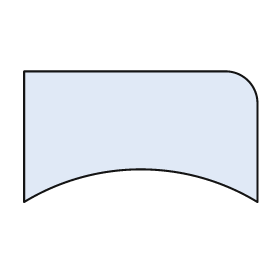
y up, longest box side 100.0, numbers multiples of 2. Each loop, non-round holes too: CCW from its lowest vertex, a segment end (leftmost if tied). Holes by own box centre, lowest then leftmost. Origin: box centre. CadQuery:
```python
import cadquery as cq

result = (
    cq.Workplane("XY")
    .moveTo(-50.0, -28.0)
    .threePointArc((0.0, -14.0), (50.0, -28.0))
    .lineTo(50.0, 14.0)
    .threePointArc((46.0, 24.0), (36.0, 28.0))
    .lineTo(-50.0, 28.0)
    .close()
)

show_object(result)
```